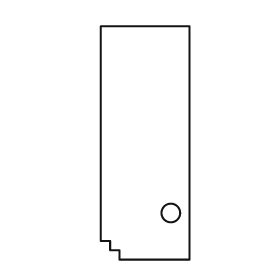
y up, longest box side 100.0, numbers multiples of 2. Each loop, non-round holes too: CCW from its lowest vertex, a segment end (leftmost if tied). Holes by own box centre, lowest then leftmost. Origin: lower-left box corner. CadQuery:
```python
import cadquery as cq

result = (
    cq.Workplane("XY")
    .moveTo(8.0, 0.0)
    .lineTo(38.0, 0.0)
    .lineTo(38.0, 100.0)
    .lineTo(0.0, 100.0)
    .lineTo(0.0, 8.0)
    .lineTo(4.0, 8.0)
    .lineTo(4.0, 4.0)
    .lineTo(8.0, 4.0)
    .close()
    .moveTo(30.0, 20.0)
    .circle(4.0)
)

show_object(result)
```